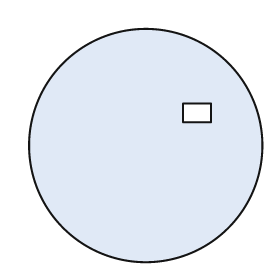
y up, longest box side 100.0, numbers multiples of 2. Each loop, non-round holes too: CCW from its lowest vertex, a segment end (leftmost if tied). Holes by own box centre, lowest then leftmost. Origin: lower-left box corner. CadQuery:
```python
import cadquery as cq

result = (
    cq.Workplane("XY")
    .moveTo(50.0, 50.0)
    .circle(50.0)
    .moveTo(66.0, 60.0)
    .lineTo(78.0, 60.0)
    .lineTo(78.0, 68.0)
    .lineTo(66.0, 68.0)
    .close()
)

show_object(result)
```